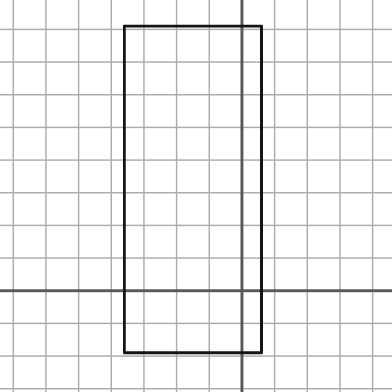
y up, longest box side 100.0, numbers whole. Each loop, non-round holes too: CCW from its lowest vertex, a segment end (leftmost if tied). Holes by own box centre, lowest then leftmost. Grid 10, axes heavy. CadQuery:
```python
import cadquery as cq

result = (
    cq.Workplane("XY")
    .moveTo(-36.0, -19.0)
    .lineTo(6.0, -19.0)
    .lineTo(6.0, 81.0)
    .lineTo(-36.0, 81.0)
    .close()
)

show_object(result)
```